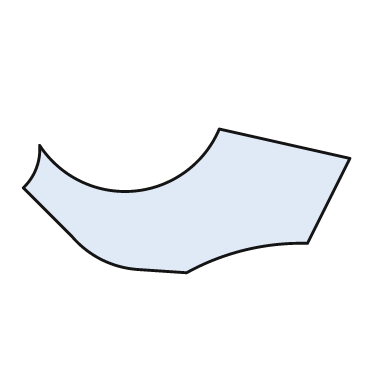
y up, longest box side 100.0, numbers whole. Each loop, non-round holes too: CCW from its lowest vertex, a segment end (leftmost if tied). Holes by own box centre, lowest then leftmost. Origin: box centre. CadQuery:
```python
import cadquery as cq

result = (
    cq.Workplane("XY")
    .moveTo(0.0, -22.0)
    .threePointArc((18.0, -15.0), (37.0, -13.0))
    .lineTo(50.0, 13.0)
    .lineTo(10.0, 22.0)
    .threePointArc((-16.0, 3.0), (-45.0, 17.0))
    .threePointArc((-46.0, 10.0), (-50.0, 4.0))
    .lineTo(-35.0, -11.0)
    .threePointArc((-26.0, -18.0), (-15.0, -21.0))
    .close()
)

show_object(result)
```